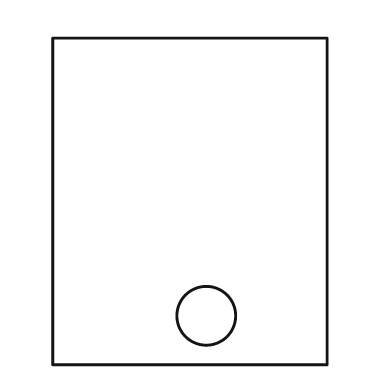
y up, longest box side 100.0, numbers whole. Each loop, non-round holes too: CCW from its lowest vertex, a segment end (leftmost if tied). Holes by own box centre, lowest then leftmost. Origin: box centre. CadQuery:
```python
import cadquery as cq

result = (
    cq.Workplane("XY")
    .moveTo(-42.0, -50.0)
    .lineTo(42.0, -50.0)
    .lineTo(42.0, 50.0)
    .lineTo(-42.0, 50.0)
    .close()
    .moveTo(5.0, -35.0)
    .circle(9.0)
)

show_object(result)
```